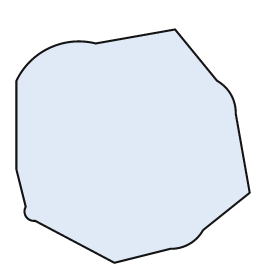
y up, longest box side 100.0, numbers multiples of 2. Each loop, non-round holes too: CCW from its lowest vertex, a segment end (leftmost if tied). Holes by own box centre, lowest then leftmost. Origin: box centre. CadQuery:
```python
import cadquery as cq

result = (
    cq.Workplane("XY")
    .moveTo(-8.0, -50.0)
    .lineTo(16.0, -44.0)
    .threePointArc((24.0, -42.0), (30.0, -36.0))
    .lineTo(50.0, -20.0)
    .lineTo(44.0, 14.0)
    .threePointArc((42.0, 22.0), (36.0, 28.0))
    .lineTo(18.0, 50.0)
    .lineTo(-16.0, 44.0)
    .threePointArc((-36.0, 42.0), (-50.0, 28.0))
    .lineTo(-50.0, -10.0)
    .lineTo(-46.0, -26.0)
    .threePointArc((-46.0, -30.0), (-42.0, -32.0))
    .close()
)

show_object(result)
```